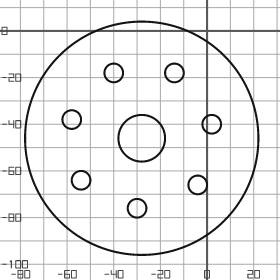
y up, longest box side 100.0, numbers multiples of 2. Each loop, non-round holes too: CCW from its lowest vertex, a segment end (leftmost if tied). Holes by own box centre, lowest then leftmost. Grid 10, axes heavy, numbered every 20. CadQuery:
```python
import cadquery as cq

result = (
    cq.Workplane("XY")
    .moveTo(-28.0, -46.0)
    .circle(50.0)
    .moveTo(-30.0, -76.0)
    .circle(4.0)
    .moveTo(-4.0, -66.0)
    .circle(4.0)
    .moveTo(-54.0, -64.0)
    .circle(4.0)
    .moveTo(-28.0, -46.0)
    .circle(10.0)
    .moveTo(2.0, -40.0)
    .circle(4.0)
    .moveTo(-58.0, -38.0)
    .circle(4.0)
    .moveTo(-40.0, -18.0)
    .circle(4.0)
    .moveTo(-14.0, -18.0)
    .circle(4.0)
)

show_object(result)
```